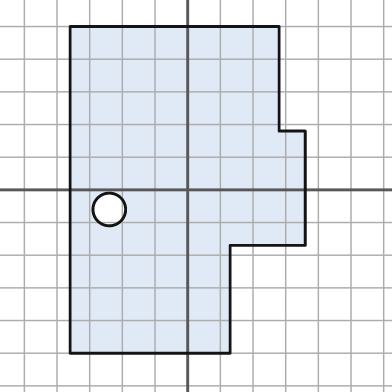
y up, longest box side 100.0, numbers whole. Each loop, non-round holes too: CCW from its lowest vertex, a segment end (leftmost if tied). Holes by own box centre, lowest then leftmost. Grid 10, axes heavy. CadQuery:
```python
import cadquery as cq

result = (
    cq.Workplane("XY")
    .moveTo(-36.0, -50.0)
    .lineTo(13.0, -50.0)
    .lineTo(13.0, -17.0)
    .lineTo(36.0, -17.0)
    .lineTo(36.0, 18.0)
    .lineTo(28.0, 18.0)
    .lineTo(28.0, 50.0)
    .lineTo(-36.0, 50.0)
    .close()
    .moveTo(-24.0, -6.0)
    .circle(5.0)
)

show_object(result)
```